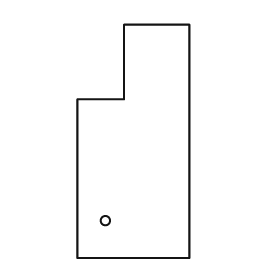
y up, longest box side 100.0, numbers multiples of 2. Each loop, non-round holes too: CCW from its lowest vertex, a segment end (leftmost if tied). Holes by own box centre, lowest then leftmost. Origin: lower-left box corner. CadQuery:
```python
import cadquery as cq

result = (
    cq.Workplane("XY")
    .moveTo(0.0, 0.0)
    .lineTo(48.0, 0.0)
    .lineTo(48.0, 100.0)
    .lineTo(20.0, 100.0)
    .lineTo(20.0, 68.0)
    .lineTo(0.0, 68.0)
    .close()
    .moveTo(12.0, 16.0)
    .circle(2.0)
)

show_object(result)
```